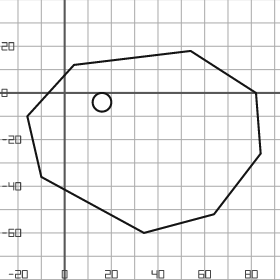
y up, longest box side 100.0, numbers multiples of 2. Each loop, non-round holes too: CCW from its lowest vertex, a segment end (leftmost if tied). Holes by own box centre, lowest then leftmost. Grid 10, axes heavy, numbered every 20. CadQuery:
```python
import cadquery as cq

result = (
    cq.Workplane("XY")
    .moveTo(34.0, -60.0)
    .lineTo(64.0, -52.0)
    .lineTo(84.0, -26.0)
    .lineTo(82.0, 0.0)
    .lineTo(54.0, 18.0)
    .lineTo(4.0, 12.0)
    .lineTo(-16.0, -10.0)
    .lineTo(-10.0, -36.0)
    .close()
    .moveTo(16.0, -4.0)
    .circle(4.0)
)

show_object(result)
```